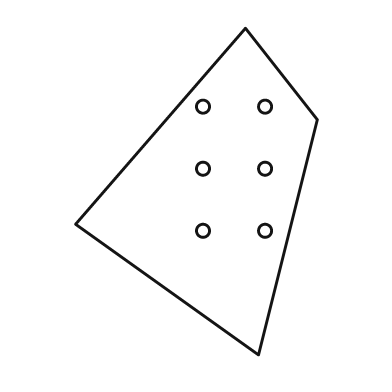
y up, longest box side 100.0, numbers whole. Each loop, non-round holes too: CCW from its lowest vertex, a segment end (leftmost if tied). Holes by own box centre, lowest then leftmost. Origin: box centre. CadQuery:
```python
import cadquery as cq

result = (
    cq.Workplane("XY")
    .moveTo(19.0, -50.0)
    .lineTo(37.0, 22.0)
    .lineTo(15.0, 50.0)
    .lineTo(-37.0, -10.0)
    .close()
    .moveTo(2.0, -12.0)
    .circle(2.0)
    .moveTo(21.0, -12.0)
    .circle(2.0)
    .moveTo(2.0, 7.0)
    .circle(2.0)
    .moveTo(21.0, 7.0)
    .circle(2.0)
    .moveTo(2.0, 26.0)
    .circle(2.0)
    .moveTo(21.0, 26.0)
    .circle(2.0)
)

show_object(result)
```